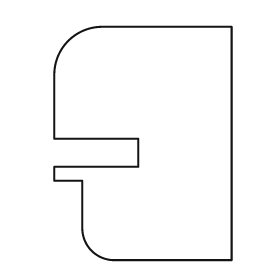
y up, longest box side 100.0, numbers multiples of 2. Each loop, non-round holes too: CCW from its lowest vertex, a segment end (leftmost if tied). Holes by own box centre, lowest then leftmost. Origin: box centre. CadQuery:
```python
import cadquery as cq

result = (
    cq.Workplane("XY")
    .moveTo(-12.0, -50.0)
    .lineTo(38.0, -50.0)
    .lineTo(38.0, 50.0)
    .lineTo(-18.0, 50.0)
    .threePointArc((-32.0, 44.0), (-38.0, 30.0))
    .lineTo(-38.0, 2.0)
    .lineTo(-2.0, 2.0)
    .lineTo(-2.0, -10.0)
    .lineTo(-38.0, -10.0)
    .lineTo(-38.0, -16.0)
    .lineTo(-26.0, -16.0)
    .lineTo(-26.0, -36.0)
    .threePointArc((-22.0, -46.0), (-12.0, -50.0))
    .close()
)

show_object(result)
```